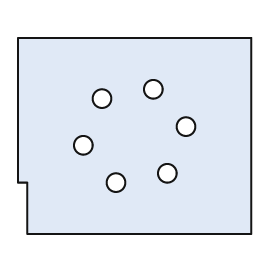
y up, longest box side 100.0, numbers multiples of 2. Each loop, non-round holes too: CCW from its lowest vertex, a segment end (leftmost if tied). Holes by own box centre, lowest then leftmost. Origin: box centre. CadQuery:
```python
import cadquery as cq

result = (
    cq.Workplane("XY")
    .moveTo(-46.0, -42.0)
    .lineTo(50.0, -42.0)
    .lineTo(50.0, 42.0)
    .lineTo(-50.0, 42.0)
    .lineTo(-50.0, -20.0)
    .lineTo(-46.0, -20.0)
    .close()
    .moveTo(-8.0, -20.0)
    .circle(4.0)
    .moveTo(14.0, -16.0)
    .circle(4.0)
    .moveTo(-22.0, -4.0)
    .circle(4.0)
    .moveTo(22.0, 4.0)
    .circle(4.0)
    .moveTo(-14.0, 16.0)
    .circle(4.0)
    .moveTo(8.0, 20.0)
    .circle(4.0)
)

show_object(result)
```